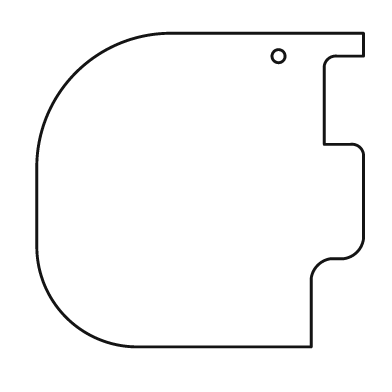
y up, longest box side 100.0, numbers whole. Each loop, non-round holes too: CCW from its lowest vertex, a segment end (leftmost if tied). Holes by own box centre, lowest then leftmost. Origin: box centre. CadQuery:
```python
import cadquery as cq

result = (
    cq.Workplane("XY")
    .moveTo(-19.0, -48.0)
    .lineTo(34.0, -48.0)
    .lineTo(34.0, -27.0)
    .threePointArc((36.0, -23.0), (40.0, -21.0))
    .lineTo(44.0, -21.0)
    .threePointArc((48.0, -19.0), (50.0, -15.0))
    .lineTo(50.0, 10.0)
    .threePointArc((49.0, 13.0), (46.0, 14.0))
    .lineTo(38.0, 14.0)
    .lineTo(38.0, 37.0)
    .threePointArc((39.0, 40.0), (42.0, 41.0))
    .lineTo(50.0, 41.0)
    .lineTo(50.0, 48.0)
    .lineTo(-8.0, 48.0)
    .threePointArc((-38.0, 36.0), (-50.0, 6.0))
    .lineTo(-50.0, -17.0)
    .threePointArc((-41.0, -39.0), (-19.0, -48.0))
    .close()
    .moveTo(24.0, 41.0)
    .circle(2.0)
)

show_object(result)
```